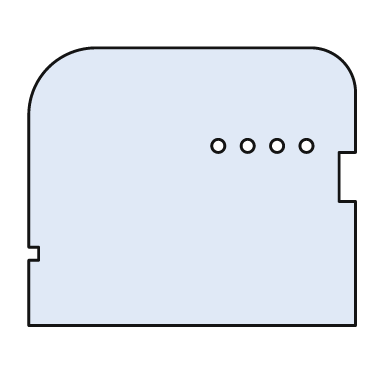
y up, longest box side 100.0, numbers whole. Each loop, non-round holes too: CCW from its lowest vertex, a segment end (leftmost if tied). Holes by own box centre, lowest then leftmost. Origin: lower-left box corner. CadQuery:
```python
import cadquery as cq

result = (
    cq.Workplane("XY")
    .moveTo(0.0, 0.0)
    .lineTo(100.0, 0.0)
    .lineTo(100.0, 38.0)
    .lineTo(95.0, 38.0)
    .lineTo(95.0, 53.0)
    .lineTo(100.0, 53.0)
    .lineTo(100.0, 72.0)
    .threePointArc((96.0, 81.0), (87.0, 85.0))
    .lineTo(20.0, 85.0)
    .threePointArc((6.0, 79.0), (0.0, 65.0))
    .lineTo(0.0, 24.0)
    .lineTo(3.0, 24.0)
    .lineTo(3.0, 20.0)
    .lineTo(0.0, 20.0)
    .close()
    .moveTo(58.0, 55.0)
    .circle(2.0)
    .moveTo(67.0, 55.0)
    .circle(2.0)
    .moveTo(76.0, 55.0)
    .circle(2.0)
    .moveTo(85.0, 55.0)
    .circle(2.0)
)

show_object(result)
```